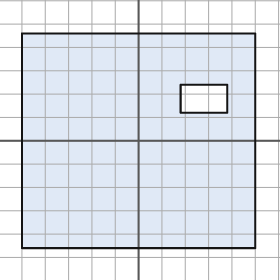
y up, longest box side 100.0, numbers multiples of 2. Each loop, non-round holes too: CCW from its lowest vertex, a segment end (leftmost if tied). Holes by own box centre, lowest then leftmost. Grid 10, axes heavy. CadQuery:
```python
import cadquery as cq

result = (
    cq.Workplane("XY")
    .moveTo(-50.0, -46.0)
    .lineTo(50.0, -46.0)
    .lineTo(50.0, 46.0)
    .lineTo(-50.0, 46.0)
    .close()
    .moveTo(18.0, 12.0)
    .lineTo(38.0, 12.0)
    .lineTo(38.0, 24.0)
    .lineTo(18.0, 24.0)
    .close()
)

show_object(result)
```